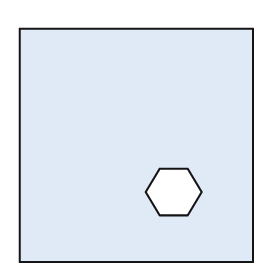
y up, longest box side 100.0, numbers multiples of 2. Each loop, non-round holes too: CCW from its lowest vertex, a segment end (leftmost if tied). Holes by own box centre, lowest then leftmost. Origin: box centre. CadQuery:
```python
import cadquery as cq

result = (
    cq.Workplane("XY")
    .moveTo(-50.0, -50.0)
    .lineTo(50.0, -50.0)
    .lineTo(50.0, 50.0)
    .lineTo(-50.0, 50.0)
    .close()
    .moveTo(10.0, -30.0)
    .lineTo(22.0, -30.0)
    .lineTo(28.0, -20.0)
    .lineTo(22.0, -10.0)
    .lineTo(10.0, -10.0)
    .lineTo(4.0, -20.0)
    .close()
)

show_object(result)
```